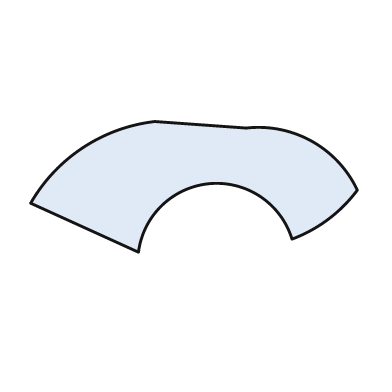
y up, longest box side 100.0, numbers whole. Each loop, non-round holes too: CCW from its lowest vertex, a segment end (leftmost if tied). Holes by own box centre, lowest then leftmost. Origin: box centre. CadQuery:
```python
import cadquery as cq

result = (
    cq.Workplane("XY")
    .moveTo(-17.0, -20.0)
    .threePointArc((5.0, 1.0), (30.0, -16.0))
    .threePointArc((41.0, -10.0), (50.0, -1.0))
    .threePointArc((36.0, 14.0), (16.0, 18.0))
    .lineTo(-12.0, 20.0)
    .threePointArc((-34.0, 12.0), (-50.0, -5.0))
    .close()
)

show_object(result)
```